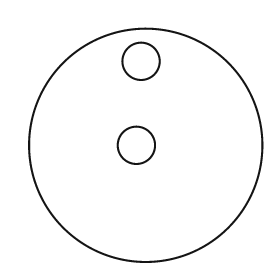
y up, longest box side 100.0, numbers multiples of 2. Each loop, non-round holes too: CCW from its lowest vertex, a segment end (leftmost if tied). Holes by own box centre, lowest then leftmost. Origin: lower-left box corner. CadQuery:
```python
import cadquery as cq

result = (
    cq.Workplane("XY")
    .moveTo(50.0, 50.0)
    .circle(50.0)
    .moveTo(46.0, 50.0)
    .circle(8.0)
    .moveTo(48.0, 86.0)
    .circle(8.0)
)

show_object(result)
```